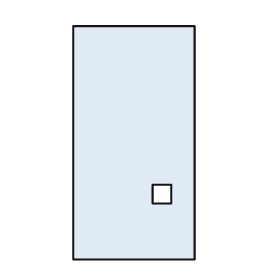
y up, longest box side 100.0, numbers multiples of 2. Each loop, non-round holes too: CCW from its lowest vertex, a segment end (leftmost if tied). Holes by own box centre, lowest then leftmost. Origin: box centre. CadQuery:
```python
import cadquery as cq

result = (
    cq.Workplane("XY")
    .moveTo(-26.0, -50.0)
    .lineTo(26.0, -50.0)
    .lineTo(26.0, 50.0)
    .lineTo(-26.0, 50.0)
    .close()
    .moveTo(8.0, -26.0)
    .lineTo(16.0, -26.0)
    .lineTo(16.0, -18.0)
    .lineTo(8.0, -18.0)
    .close()
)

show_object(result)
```